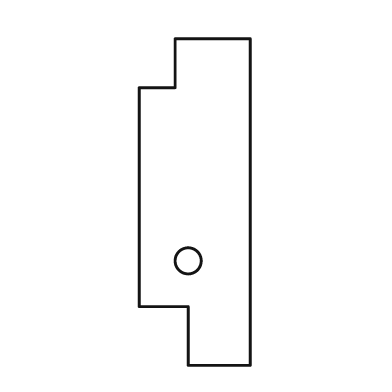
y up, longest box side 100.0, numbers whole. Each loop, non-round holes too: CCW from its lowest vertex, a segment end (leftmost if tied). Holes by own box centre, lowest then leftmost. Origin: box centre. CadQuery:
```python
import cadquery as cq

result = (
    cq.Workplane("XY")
    .moveTo(-2.0, -50.0)
    .lineTo(17.0, -50.0)
    .lineTo(17.0, 50.0)
    .lineTo(-6.0, 50.0)
    .lineTo(-6.0, 35.0)
    .lineTo(-17.0, 35.0)
    .lineTo(-17.0, -32.0)
    .lineTo(-2.0, -32.0)
    .close()
    .moveTo(-2.0, -18.0)
    .circle(4.0)
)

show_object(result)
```